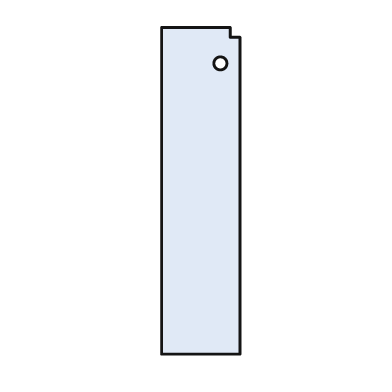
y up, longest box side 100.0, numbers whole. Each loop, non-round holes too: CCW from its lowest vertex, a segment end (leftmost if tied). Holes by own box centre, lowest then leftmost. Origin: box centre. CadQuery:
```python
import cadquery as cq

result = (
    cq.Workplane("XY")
    .moveTo(-12.0, -50.0)
    .lineTo(12.0, -50.0)
    .lineTo(12.0, 47.0)
    .lineTo(9.0, 47.0)
    .lineTo(9.0, 50.0)
    .lineTo(-12.0, 50.0)
    .close()
    .moveTo(6.0, 39.0)
    .circle(2.0)
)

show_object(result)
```